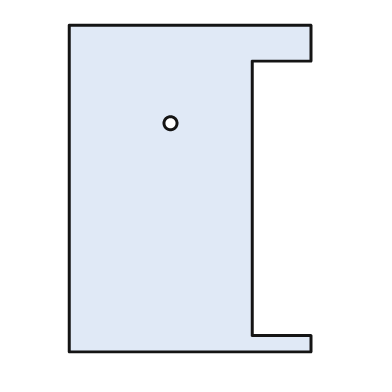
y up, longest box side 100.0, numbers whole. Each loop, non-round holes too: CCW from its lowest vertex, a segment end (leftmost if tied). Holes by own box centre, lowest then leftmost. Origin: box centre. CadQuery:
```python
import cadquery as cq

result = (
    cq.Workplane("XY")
    .moveTo(-37.0, -50.0)
    .lineTo(37.0, -50.0)
    .lineTo(37.0, -45.0)
    .lineTo(19.0, -45.0)
    .lineTo(19.0, 39.0)
    .lineTo(37.0, 39.0)
    .lineTo(37.0, 50.0)
    .lineTo(-37.0, 50.0)
    .close()
    .moveTo(-6.0, 20.0)
    .circle(2.0)
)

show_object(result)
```